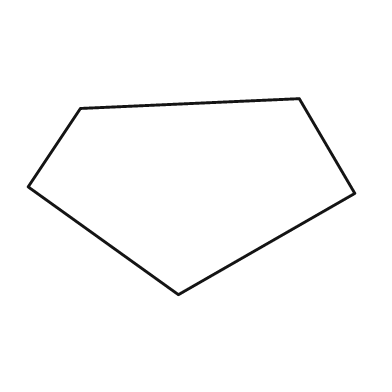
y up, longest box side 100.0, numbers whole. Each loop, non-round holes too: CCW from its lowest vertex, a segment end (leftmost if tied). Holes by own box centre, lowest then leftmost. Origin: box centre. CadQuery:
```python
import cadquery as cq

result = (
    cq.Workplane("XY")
    .moveTo(-4.0, -30.0)
    .lineTo(50.0, 1.0)
    .lineTo(33.0, 30.0)
    .lineTo(-34.0, 27.0)
    .lineTo(-50.0, 3.0)
    .close()
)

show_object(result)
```